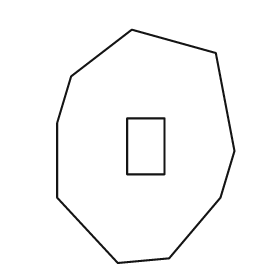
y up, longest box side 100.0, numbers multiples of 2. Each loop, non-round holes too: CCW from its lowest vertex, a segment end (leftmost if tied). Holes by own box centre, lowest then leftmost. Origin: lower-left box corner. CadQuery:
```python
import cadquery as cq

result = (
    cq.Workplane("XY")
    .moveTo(26.0, 0.0)
    .lineTo(48.0, 2.0)
    .lineTo(70.0, 28.0)
    .lineTo(76.0, 48.0)
    .lineTo(68.0, 90.0)
    .lineTo(32.0, 100.0)
    .lineTo(6.0, 80.0)
    .lineTo(0.0, 60.0)
    .lineTo(0.0, 28.0)
    .close()
    .moveTo(30.0, 38.0)
    .lineTo(46.0, 38.0)
    .lineTo(46.0, 62.0)
    .lineTo(30.0, 62.0)
    .close()
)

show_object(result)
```